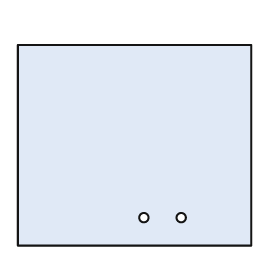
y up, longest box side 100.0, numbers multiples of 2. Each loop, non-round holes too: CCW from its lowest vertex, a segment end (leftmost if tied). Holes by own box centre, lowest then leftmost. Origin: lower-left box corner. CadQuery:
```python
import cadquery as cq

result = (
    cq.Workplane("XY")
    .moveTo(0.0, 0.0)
    .lineTo(100.0, 0.0)
    .lineTo(100.0, 86.0)
    .lineTo(0.0, 86.0)
    .close()
    .moveTo(54.0, 12.0)
    .circle(2.0)
    .moveTo(70.0, 12.0)
    .circle(2.0)
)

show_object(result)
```